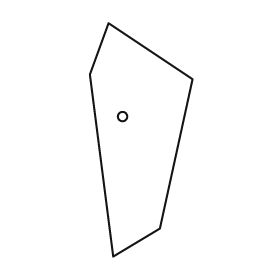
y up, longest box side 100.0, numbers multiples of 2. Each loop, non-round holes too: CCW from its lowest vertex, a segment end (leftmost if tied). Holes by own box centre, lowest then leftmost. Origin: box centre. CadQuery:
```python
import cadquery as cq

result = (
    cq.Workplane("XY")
    .moveTo(-12.0, -50.0)
    .lineTo(8.0, -38.0)
    .lineTo(22.0, 26.0)
    .lineTo(-14.0, 50.0)
    .lineTo(-22.0, 28.0)
    .close()
    .moveTo(-8.0, 10.0)
    .circle(2.0)
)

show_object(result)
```